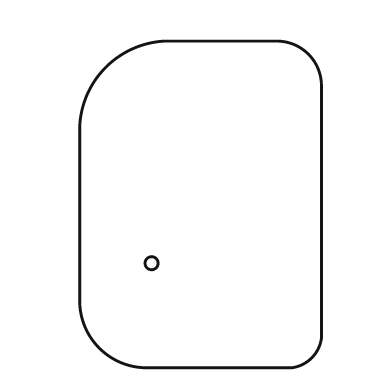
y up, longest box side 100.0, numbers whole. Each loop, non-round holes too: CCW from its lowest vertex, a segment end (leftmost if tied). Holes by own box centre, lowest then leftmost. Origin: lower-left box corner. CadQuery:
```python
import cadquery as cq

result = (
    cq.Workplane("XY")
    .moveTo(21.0, 0.0)
    .lineTo(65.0, 0.0)
    .threePointArc((71.0, 3.0), (74.0, 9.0))
    .lineTo(74.0, 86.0)
    .threePointArc((70.0, 96.0), (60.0, 100.0))
    .lineTo(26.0, 100.0)
    .threePointArc((8.0, 92.0), (0.0, 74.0))
    .lineTo(0.0, 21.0)
    .threePointArc((6.0, 6.0), (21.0, 0.0))
    .close()
    .moveTo(22.0, 32.0)
    .circle(2.0)
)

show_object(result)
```